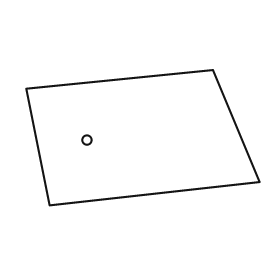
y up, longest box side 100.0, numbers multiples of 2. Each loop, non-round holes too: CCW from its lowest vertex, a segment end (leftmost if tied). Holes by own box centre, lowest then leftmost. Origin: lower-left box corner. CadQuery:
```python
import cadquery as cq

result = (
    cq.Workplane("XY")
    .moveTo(10.0, 0.0)
    .lineTo(100.0, 10.0)
    .lineTo(80.0, 58.0)
    .lineTo(0.0, 50.0)
    .close()
    .moveTo(26.0, 28.0)
    .circle(2.0)
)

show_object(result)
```